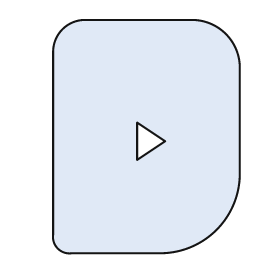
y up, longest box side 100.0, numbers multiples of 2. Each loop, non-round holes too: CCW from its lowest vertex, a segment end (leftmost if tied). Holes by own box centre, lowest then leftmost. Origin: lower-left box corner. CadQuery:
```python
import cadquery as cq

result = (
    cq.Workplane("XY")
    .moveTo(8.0, 0.0)
    .lineTo(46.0, 0.0)
    .threePointArc((70.0, 10.0), (80.0, 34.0))
    .lineTo(80.0, 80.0)
    .threePointArc((74.0, 94.0), (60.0, 100.0))
    .lineTo(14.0, 100.0)
    .threePointArc((4.0, 96.0), (0.0, 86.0))
    .lineTo(0.0, 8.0)
    .threePointArc((2.0, 2.0), (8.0, 0.0))
    .close()
    .moveTo(36.0, 40.0)
    .lineTo(48.0, 48.0)
    .lineTo(36.0, 56.0)
    .close()
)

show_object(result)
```